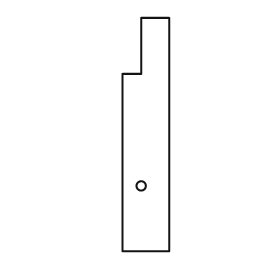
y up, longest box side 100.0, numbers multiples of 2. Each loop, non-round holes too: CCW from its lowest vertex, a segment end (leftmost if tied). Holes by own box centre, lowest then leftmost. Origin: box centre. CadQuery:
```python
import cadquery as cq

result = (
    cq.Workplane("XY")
    .moveTo(-10.0, -50.0)
    .lineTo(10.0, -50.0)
    .lineTo(10.0, 50.0)
    .lineTo(-2.0, 50.0)
    .lineTo(-2.0, 26.0)
    .lineTo(-10.0, 26.0)
    .close()
    .moveTo(-2.0, -22.0)
    .circle(2.0)
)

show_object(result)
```